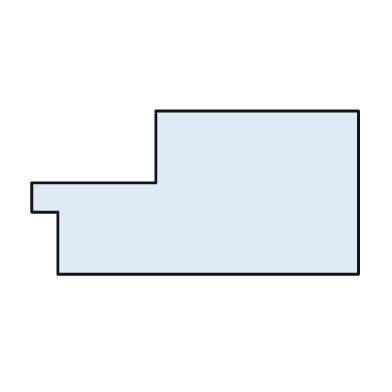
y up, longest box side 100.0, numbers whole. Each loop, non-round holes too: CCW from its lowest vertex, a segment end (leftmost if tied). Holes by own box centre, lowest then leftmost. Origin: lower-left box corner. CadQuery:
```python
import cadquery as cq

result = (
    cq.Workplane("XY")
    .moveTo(8.0, 0.0)
    .lineTo(100.0, 0.0)
    .lineTo(100.0, 50.0)
    .lineTo(38.0, 50.0)
    .lineTo(38.0, 28.0)
    .lineTo(0.0, 28.0)
    .lineTo(0.0, 19.0)
    .lineTo(8.0, 19.0)
    .close()
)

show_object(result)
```